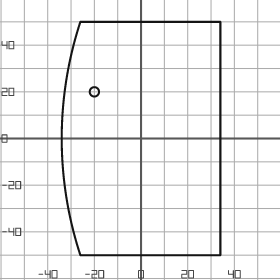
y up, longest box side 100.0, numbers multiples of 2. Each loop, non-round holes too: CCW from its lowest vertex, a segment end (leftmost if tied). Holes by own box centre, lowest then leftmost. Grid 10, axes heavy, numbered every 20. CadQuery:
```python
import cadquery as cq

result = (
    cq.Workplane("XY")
    .moveTo(-26.0, -50.0)
    .lineTo(34.0, -50.0)
    .lineTo(34.0, 50.0)
    .lineTo(-26.0, 50.0)
    .threePointArc((-34.0, 0.0), (-26.0, -50.0))
    .close()
    .moveTo(-20.0, 20.0)
    .circle(2.0)
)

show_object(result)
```